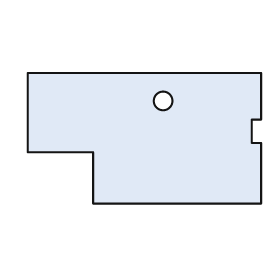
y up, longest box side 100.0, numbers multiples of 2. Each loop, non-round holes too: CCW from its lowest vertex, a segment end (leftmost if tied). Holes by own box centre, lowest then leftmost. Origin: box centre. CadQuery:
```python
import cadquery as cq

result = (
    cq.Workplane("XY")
    .moveTo(-22.0, -28.0)
    .lineTo(50.0, -28.0)
    .lineTo(50.0, -2.0)
    .lineTo(46.0, -2.0)
    .lineTo(46.0, 8.0)
    .lineTo(50.0, 8.0)
    .lineTo(50.0, 28.0)
    .lineTo(-50.0, 28.0)
    .lineTo(-50.0, -6.0)
    .lineTo(-22.0, -6.0)
    .close()
    .moveTo(8.0, 16.0)
    .circle(4.0)
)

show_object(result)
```